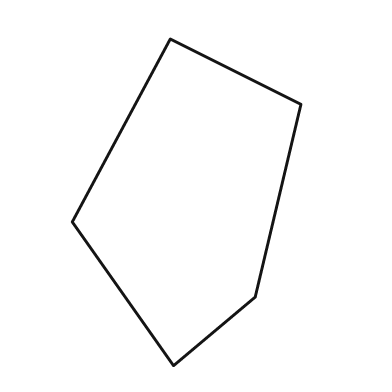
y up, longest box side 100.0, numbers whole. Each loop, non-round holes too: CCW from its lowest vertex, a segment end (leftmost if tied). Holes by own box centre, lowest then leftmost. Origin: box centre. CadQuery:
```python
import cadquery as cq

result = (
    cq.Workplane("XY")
    .moveTo(-4.0, -50.0)
    .lineTo(21.0, -29.0)
    .lineTo(35.0, 30.0)
    .lineTo(-5.0, 50.0)
    .lineTo(-35.0, -6.0)
    .close()
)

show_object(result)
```